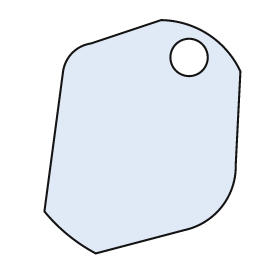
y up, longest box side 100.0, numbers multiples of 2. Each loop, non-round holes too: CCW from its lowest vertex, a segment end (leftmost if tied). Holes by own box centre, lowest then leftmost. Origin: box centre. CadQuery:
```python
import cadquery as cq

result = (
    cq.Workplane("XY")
    .moveTo(-20.0, -50.0)
    .lineTo(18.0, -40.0)
    .threePointArc((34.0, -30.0), (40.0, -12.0))
    .lineTo(42.0, 28.0)
    .threePointArc((28.0, 44.0), (8.0, 50.0))
    .lineTo(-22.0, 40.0)
    .threePointArc((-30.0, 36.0), (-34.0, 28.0))
    .lineTo(-42.0, -32.0)
    .threePointArc((-32.0, -42.0), (-20.0, -50.0))
    .close()
    .moveTo(20.0, 34.0)
    .circle(8.0)
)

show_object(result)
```